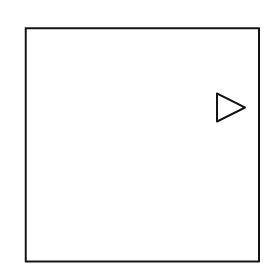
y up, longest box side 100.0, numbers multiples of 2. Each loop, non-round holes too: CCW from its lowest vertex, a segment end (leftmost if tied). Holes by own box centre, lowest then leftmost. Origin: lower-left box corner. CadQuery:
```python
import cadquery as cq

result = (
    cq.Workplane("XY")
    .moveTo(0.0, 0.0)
    .lineTo(100.0, 0.0)
    .lineTo(100.0, 100.0)
    .lineTo(0.0, 100.0)
    .close()
    .moveTo(82.0, 60.0)
    .lineTo(94.0, 66.0)
    .lineTo(82.0, 72.0)
    .close()
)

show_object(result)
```